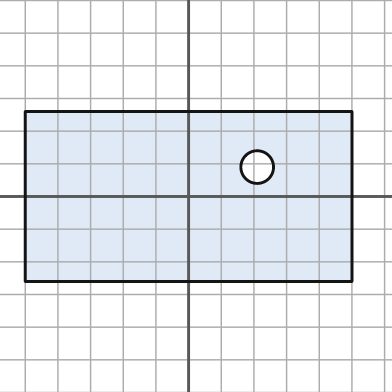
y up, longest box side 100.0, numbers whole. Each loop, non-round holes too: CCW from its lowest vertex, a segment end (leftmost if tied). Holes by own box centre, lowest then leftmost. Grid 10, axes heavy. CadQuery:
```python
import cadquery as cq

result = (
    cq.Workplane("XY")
    .moveTo(-50.0, -26.0)
    .lineTo(50.0, -26.0)
    .lineTo(50.0, 26.0)
    .lineTo(-50.0, 26.0)
    .close()
    .moveTo(21.0, 9.0)
    .circle(5.0)
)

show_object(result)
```